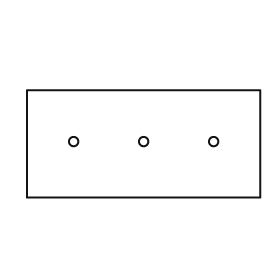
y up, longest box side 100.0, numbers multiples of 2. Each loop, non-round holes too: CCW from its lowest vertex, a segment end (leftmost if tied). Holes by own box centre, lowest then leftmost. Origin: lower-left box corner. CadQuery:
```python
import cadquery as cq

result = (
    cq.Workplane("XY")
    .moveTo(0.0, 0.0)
    .lineTo(100.0, 0.0)
    .lineTo(100.0, 46.0)
    .lineTo(0.0, 46.0)
    .close()
    .moveTo(20.0, 24.0)
    .circle(2.0)
    .moveTo(50.0, 24.0)
    .circle(2.0)
    .moveTo(80.0, 24.0)
    .circle(2.0)
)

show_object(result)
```